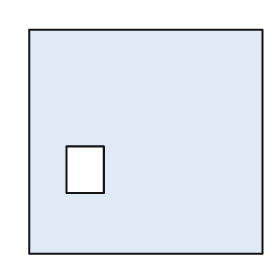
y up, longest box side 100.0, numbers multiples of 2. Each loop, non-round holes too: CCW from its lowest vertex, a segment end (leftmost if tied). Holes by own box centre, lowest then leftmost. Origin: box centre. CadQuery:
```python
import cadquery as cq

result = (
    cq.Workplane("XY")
    .moveTo(-50.0, -48.0)
    .lineTo(50.0, -48.0)
    .lineTo(50.0, 48.0)
    .lineTo(-50.0, 48.0)
    .close()
    .moveTo(-34.0, -22.0)
    .lineTo(-18.0, -22.0)
    .lineTo(-18.0, -2.0)
    .lineTo(-34.0, -2.0)
    .close()
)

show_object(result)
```